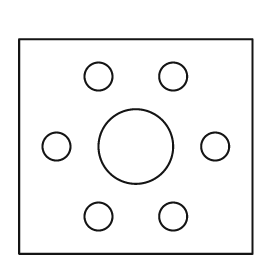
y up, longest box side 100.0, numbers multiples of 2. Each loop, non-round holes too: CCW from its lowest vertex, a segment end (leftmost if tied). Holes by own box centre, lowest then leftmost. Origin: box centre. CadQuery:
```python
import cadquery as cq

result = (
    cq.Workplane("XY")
    .moveTo(-50.0, -46.0)
    .lineTo(50.0, -46.0)
    .lineTo(50.0, 46.0)
    .lineTo(-50.0, 46.0)
    .close()
    .moveTo(-16.0, -30.0)
    .circle(6.0)
    .moveTo(16.0, -30.0)
    .circle(6.0)
    .moveTo(-34.0, 0.0)
    .circle(6.0)
    .moveTo(0.0, 0.0)
    .circle(16.0)
    .moveTo(34.0, 0.0)
    .circle(6.0)
    .moveTo(-16.0, 30.0)
    .circle(6.0)
    .moveTo(16.0, 30.0)
    .circle(6.0)
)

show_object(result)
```